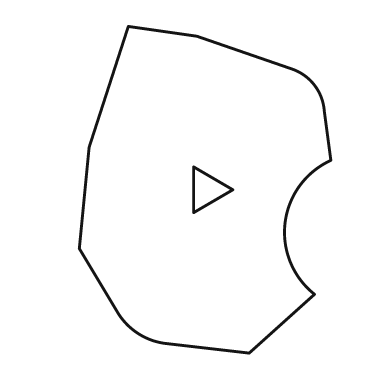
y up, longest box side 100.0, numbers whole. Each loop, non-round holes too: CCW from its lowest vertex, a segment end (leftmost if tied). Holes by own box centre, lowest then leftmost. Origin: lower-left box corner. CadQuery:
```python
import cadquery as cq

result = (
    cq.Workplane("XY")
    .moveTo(52.0, 0.0)
    .lineTo(72.0, 18.0)
    .threePointArc((63.0, 40.0), (77.0, 59.0))
    .lineTo(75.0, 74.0)
    .threePointArc((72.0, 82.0), (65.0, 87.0))
    .lineTo(36.0, 97.0)
    .lineTo(15.0, 100.0)
    .lineTo(3.0, 63.0)
    .lineTo(0.0, 32.0)
    .lineTo(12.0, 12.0)
    .threePointArc((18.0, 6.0), (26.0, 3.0))
    .close()
    .moveTo(35.0, 43.0)
    .lineTo(47.0, 50.0)
    .lineTo(35.0, 57.0)
    .close()
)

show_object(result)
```